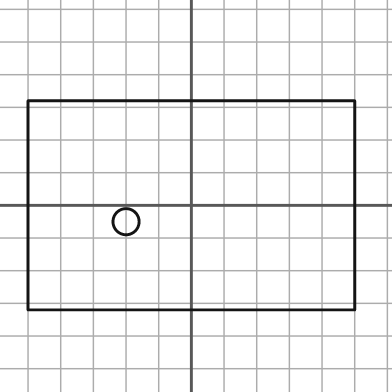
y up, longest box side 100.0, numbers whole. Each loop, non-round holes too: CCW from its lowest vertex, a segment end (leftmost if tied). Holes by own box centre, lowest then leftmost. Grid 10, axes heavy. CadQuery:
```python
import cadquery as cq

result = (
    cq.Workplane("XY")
    .moveTo(-50.0, -32.0)
    .lineTo(50.0, -32.0)
    .lineTo(50.0, 32.0)
    .lineTo(-50.0, 32.0)
    .close()
    .moveTo(-20.0, -5.0)
    .circle(4.0)
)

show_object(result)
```